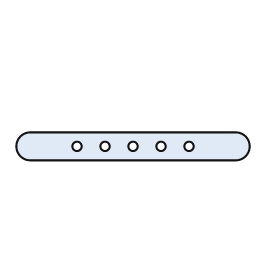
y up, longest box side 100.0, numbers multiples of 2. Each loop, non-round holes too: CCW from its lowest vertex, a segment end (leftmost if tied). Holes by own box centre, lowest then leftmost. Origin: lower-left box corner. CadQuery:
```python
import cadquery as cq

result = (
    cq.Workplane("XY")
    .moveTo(6.0, 0.0)
    .lineTo(94.0, 0.0)
    .threePointArc((100.0, 6.0), (94.0, 12.0))
    .lineTo(6.0, 12.0)
    .threePointArc((0.0, 6.0), (6.0, 0.0))
    .close()
    .moveTo(26.0, 6.0)
    .circle(2.0)
    .moveTo(38.0, 6.0)
    .circle(2.0)
    .moveTo(50.0, 6.0)
    .circle(2.0)
    .moveTo(62.0, 6.0)
    .circle(2.0)
    .moveTo(74.0, 6.0)
    .circle(2.0)
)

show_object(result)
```